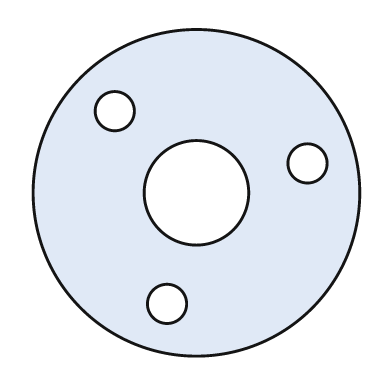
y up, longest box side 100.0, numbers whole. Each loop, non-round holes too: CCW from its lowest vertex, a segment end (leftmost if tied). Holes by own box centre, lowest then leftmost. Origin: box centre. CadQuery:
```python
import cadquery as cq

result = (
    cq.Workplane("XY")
    .moveTo(0.0, 0.0)
    .circle(50.0)
    .moveTo(-9.0, -34.0)
    .circle(6.0)
    .moveTo(0.0, 0.0)
    .circle(16.0)
    .moveTo(34.0, 9.0)
    .circle(6.0)
    .moveTo(-25.0, 25.0)
    .circle(6.0)
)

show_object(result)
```